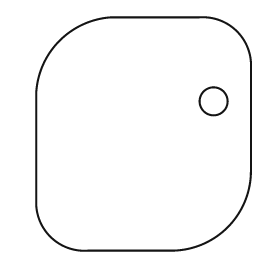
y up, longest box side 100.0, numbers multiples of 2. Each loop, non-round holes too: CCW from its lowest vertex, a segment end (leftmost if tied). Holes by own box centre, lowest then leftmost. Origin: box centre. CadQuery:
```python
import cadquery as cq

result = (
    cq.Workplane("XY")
    .moveTo(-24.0, -50.0)
    .lineTo(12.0, -50.0)
    .threePointArc((36.0, -40.0), (46.0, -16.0))
    .lineTo(46.0, 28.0)
    .threePointArc((40.0, 44.0), (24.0, 50.0))
    .lineTo(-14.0, 50.0)
    .threePointArc((-36.0, 40.0), (-46.0, 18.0))
    .lineTo(-46.0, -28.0)
    .threePointArc((-40.0, -44.0), (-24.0, -50.0))
    .close()
    .moveTo(30.0, 14.0)
    .circle(6.0)
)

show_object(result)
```